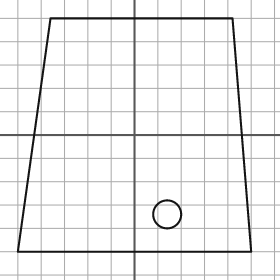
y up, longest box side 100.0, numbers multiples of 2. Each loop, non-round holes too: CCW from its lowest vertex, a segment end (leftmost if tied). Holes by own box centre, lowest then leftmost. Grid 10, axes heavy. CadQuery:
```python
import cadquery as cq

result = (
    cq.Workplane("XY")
    .moveTo(-50.0, -50.0)
    .lineTo(50.0, -50.0)
    .lineTo(42.0, 50.0)
    .lineTo(-36.0, 50.0)
    .close()
    .moveTo(14.0, -34.0)
    .circle(6.0)
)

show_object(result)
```